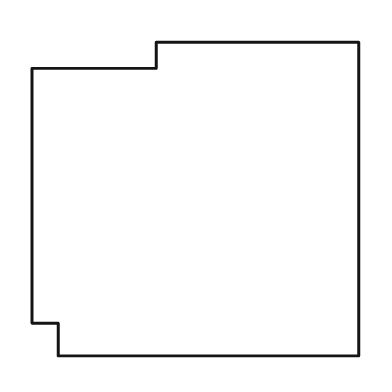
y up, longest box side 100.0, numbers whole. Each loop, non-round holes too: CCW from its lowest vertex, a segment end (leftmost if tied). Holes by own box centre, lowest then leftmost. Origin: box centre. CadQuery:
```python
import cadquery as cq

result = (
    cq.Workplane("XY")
    .moveTo(-42.0, -48.0)
    .lineTo(50.0, -48.0)
    .lineTo(50.0, 48.0)
    .lineTo(-12.0, 48.0)
    .lineTo(-12.0, 40.0)
    .lineTo(-50.0, 40.0)
    .lineTo(-50.0, -38.0)
    .lineTo(-42.0, -38.0)
    .close()
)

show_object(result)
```